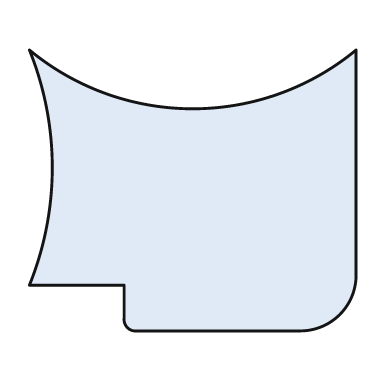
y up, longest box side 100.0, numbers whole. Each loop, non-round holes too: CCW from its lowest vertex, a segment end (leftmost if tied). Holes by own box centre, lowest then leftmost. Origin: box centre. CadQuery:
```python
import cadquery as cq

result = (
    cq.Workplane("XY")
    .moveTo(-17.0, -43.0)
    .lineTo(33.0, -43.0)
    .threePointArc((45.0, -38.0), (50.0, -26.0))
    .lineTo(50.0, 43.0)
    .threePointArc((0.0, 25.0), (-50.0, 43.0))
    .threePointArc((-43.0, 7.0), (-50.0, -29.0))
    .lineTo(-21.0, -29.0)
    .lineTo(-21.0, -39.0)
    .threePointArc((-20.0, -42.0), (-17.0, -43.0))
    .close()
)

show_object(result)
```